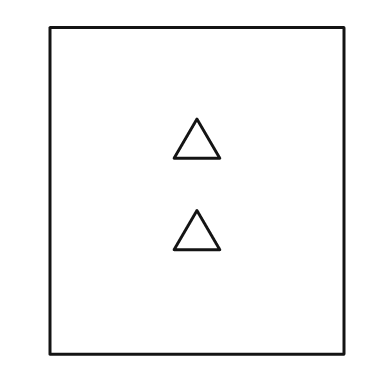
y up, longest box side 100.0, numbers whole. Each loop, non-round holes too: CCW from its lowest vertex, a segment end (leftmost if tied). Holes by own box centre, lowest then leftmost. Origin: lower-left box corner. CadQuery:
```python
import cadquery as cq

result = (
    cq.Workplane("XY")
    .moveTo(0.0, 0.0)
    .lineTo(90.0, 0.0)
    .lineTo(90.0, 100.0)
    .lineTo(0.0, 100.0)
    .close()
    .moveTo(38.0, 32.0)
    .lineTo(52.0, 32.0)
    .lineTo(45.0, 44.0)
    .close()
    .moveTo(38.0, 60.0)
    .lineTo(52.0, 60.0)
    .lineTo(45.0, 72.0)
    .close()
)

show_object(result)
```